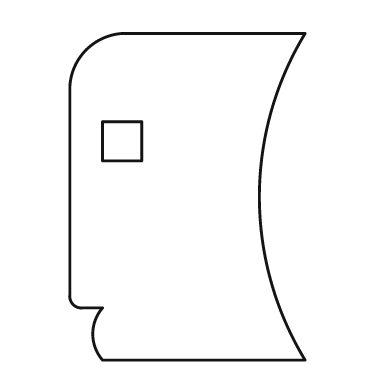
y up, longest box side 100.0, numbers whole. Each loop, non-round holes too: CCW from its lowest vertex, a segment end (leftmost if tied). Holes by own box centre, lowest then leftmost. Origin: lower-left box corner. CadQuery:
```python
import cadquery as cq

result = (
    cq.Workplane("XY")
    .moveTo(10.0, 0.0)
    .lineTo(72.0, 0.0)
    .threePointArc((58.0, 50.0), (72.0, 100.0))
    .lineTo(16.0, 100.0)
    .threePointArc((5.0, 95.0), (0.0, 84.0))
    .lineTo(0.0, 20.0)
    .threePointArc((1.0, 17.0), (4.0, 16.0))
    .lineTo(10.0, 16.0)
    .threePointArc((7.0, 8.0), (10.0, 0.0))
    .close()
    .moveTo(10.0, 61.0)
    .lineTo(22.0, 61.0)
    .lineTo(22.0, 73.0)
    .lineTo(10.0, 73.0)
    .close()
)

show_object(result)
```